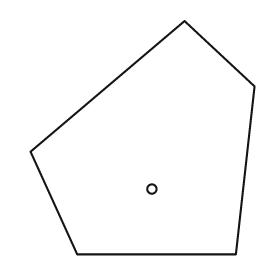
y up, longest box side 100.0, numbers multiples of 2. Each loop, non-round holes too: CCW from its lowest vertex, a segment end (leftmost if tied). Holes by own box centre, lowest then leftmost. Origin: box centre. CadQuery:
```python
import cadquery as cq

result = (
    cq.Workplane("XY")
    .moveTo(-28.0, -50.0)
    .lineTo(40.0, -50.0)
    .lineTo(48.0, 22.0)
    .lineTo(18.0, 50.0)
    .lineTo(-48.0, -6.0)
    .close()
    .moveTo(4.0, -22.0)
    .circle(2.0)
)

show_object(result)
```